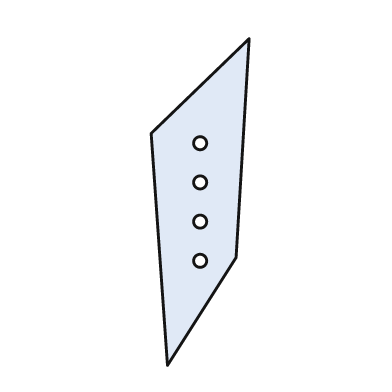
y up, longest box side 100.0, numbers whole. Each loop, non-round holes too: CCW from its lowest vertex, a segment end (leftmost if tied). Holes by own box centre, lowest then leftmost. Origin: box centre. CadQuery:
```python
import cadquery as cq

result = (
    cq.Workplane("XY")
    .moveTo(-10.0, -50.0)
    .lineTo(11.0, -17.0)
    .lineTo(15.0, 50.0)
    .lineTo(-15.0, 21.0)
    .close()
    .moveTo(0.0, -18.0)
    .circle(2.0)
    .moveTo(0.0, -6.0)
    .circle(2.0)
    .moveTo(0.0, 6.0)
    .circle(2.0)
    .moveTo(0.0, 18.0)
    .circle(2.0)
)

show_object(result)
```